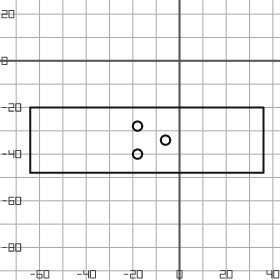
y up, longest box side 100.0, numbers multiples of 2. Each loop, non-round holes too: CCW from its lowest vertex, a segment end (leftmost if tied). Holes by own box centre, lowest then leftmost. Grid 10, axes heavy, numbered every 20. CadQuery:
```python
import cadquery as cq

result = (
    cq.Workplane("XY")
    .moveTo(-64.0, -48.0)
    .lineTo(36.0, -48.0)
    .lineTo(36.0, -20.0)
    .lineTo(-64.0, -20.0)
    .close()
    .moveTo(-18.0, -40.0)
    .circle(2.0)
    .moveTo(-6.0, -34.0)
    .circle(2.0)
    .moveTo(-18.0, -28.0)
    .circle(2.0)
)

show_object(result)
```